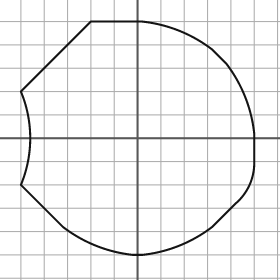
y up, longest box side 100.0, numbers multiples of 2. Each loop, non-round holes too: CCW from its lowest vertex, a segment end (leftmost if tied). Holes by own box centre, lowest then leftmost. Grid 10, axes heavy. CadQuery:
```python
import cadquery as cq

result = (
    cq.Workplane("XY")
    .moveTo(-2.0, -50.0)
    .lineTo(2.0, -50.0)
    .threePointArc((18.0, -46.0), (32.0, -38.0))
    .lineTo(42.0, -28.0)
    .threePointArc((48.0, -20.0), (50.0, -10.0))
    .lineTo(50.0, 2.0)
    .threePointArc((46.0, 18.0), (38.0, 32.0))
    .lineTo(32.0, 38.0)
    .threePointArc((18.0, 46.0), (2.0, 50.0))
    .lineTo(-20.0, 50.0)
    .lineTo(-50.0, 20.0)
    .threePointArc((-46.0, 0.0), (-50.0, -20.0))
    .lineTo(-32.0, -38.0)
    .threePointArc((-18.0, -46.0), (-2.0, -50.0))
    .close()
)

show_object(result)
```